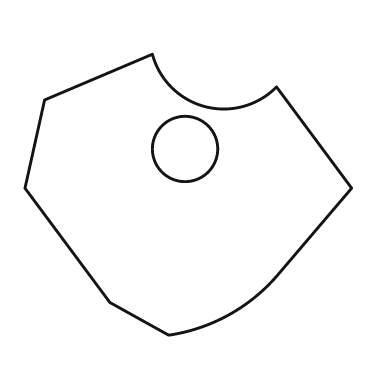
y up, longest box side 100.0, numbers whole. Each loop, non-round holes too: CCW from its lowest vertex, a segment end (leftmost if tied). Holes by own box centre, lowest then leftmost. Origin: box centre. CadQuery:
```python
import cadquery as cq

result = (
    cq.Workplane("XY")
    .moveTo(-6.0, -43.0)
    .threePointArc((12.0, -37.0), (27.0, -25.0))
    .lineTo(50.0, 2.0)
    .lineTo(27.0, 33.0)
    .threePointArc((5.0, 27.0), (-11.0, 43.0))
    .lineTo(-44.0, 29.0)
    .lineTo(-50.0, 2.0)
    .lineTo(-24.0, -33.0)
    .close()
    .moveTo(-1.0, 14.0)
    .circle(10.0)
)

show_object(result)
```